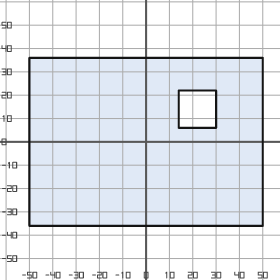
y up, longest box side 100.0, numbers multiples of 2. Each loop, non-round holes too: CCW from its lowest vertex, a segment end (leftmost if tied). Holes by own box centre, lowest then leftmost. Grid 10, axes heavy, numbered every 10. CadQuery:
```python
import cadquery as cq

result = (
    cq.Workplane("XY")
    .moveTo(-50.0, -36.0)
    .lineTo(50.0, -36.0)
    .lineTo(50.0, 36.0)
    .lineTo(-50.0, 36.0)
    .close()
    .moveTo(14.0, 6.0)
    .lineTo(30.0, 6.0)
    .lineTo(30.0, 22.0)
    .lineTo(14.0, 22.0)
    .close()
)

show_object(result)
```